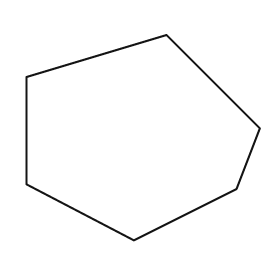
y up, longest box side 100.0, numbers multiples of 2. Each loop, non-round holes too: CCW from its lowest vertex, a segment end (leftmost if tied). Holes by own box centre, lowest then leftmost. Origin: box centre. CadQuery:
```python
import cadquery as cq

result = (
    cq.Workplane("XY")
    .moveTo(-4.0, -44.0)
    .lineTo(40.0, -22.0)
    .lineTo(50.0, 4.0)
    .lineTo(10.0, 44.0)
    .lineTo(-50.0, 26.0)
    .lineTo(-50.0, -20.0)
    .close()
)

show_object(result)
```